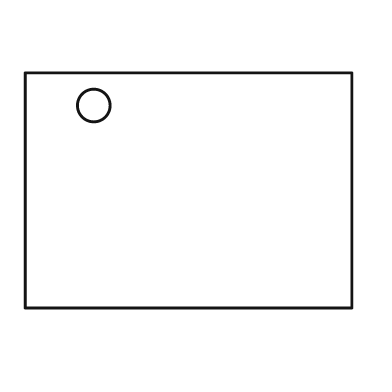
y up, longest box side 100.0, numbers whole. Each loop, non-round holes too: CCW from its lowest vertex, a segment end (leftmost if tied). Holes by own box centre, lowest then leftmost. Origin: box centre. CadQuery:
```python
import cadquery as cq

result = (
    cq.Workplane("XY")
    .moveTo(-50.0, -36.0)
    .lineTo(50.0, -36.0)
    .lineTo(50.0, 36.0)
    .lineTo(-50.0, 36.0)
    .close()
    .moveTo(-29.0, 26.0)
    .circle(5.0)
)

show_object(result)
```